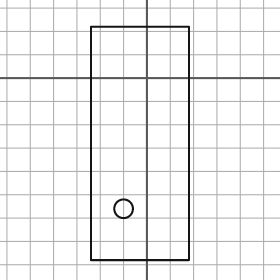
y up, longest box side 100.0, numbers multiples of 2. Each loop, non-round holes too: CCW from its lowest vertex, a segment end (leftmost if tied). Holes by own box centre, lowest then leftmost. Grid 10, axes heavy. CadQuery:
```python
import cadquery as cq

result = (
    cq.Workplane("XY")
    .moveTo(-24.0, -78.0)
    .lineTo(18.0, -78.0)
    .lineTo(18.0, 22.0)
    .lineTo(-24.0, 22.0)
    .close()
    .moveTo(-10.0, -56.0)
    .circle(4.0)
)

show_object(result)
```